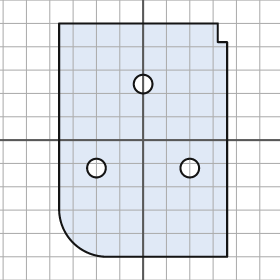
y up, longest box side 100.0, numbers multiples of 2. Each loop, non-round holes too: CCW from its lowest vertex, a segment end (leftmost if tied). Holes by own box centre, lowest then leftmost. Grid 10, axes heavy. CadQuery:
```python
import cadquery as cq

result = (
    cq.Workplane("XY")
    .moveTo(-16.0, -50.0)
    .lineTo(36.0, -50.0)
    .lineTo(36.0, 42.0)
    .lineTo(32.0, 42.0)
    .lineTo(32.0, 50.0)
    .lineTo(-36.0, 50.0)
    .lineTo(-36.0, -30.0)
    .threePointArc((-30.0, -44.0), (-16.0, -50.0))
    .close()
    .moveTo(-20.0, -12.0)
    .circle(4.0)
    .moveTo(20.0, -12.0)
    .circle(4.0)
    .moveTo(0.0, 24.0)
    .circle(4.0)
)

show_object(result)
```